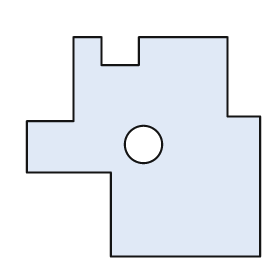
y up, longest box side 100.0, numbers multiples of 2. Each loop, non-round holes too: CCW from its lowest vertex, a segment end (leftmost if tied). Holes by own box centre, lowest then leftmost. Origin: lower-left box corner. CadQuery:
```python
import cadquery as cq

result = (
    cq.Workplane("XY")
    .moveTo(36.0, 0.0)
    .lineTo(100.0, 0.0)
    .lineTo(100.0, 60.0)
    .lineTo(86.0, 60.0)
    .lineTo(86.0, 94.0)
    .lineTo(48.0, 94.0)
    .lineTo(48.0, 82.0)
    .lineTo(32.0, 82.0)
    .lineTo(32.0, 94.0)
    .lineTo(20.0, 94.0)
    .lineTo(20.0, 58.0)
    .lineTo(0.0, 58.0)
    .lineTo(0.0, 36.0)
    .lineTo(36.0, 36.0)
    .close()
    .moveTo(50.0, 48.0)
    .circle(8.0)
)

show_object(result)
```